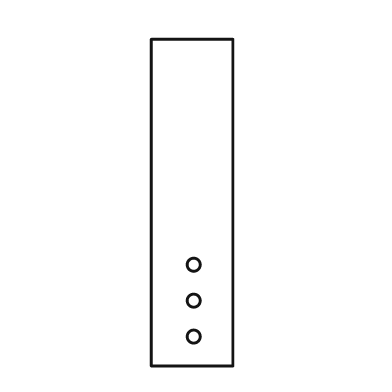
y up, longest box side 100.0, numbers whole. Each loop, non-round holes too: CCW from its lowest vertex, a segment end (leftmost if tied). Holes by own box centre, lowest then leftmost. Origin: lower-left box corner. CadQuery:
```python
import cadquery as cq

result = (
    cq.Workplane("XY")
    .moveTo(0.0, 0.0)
    .lineTo(25.0, 0.0)
    .lineTo(25.0, 100.0)
    .lineTo(0.0, 100.0)
    .close()
    .moveTo(13.0, 9.0)
    .circle(2.0)
    .moveTo(13.0, 20.0)
    .circle(2.0)
    .moveTo(13.0, 31.0)
    .circle(2.0)
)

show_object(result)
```